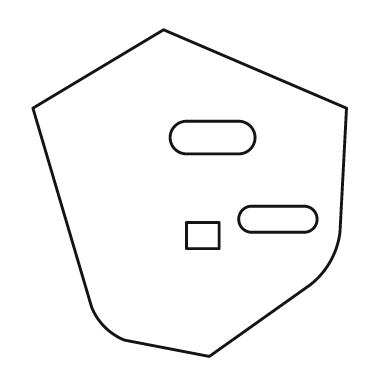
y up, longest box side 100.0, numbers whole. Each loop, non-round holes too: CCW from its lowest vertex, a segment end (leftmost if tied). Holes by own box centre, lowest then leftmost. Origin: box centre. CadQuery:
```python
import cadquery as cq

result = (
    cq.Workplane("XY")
    .moveTo(6.0, -50.0)
    .lineTo(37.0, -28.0)
    .threePointArc((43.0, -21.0), (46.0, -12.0))
    .lineTo(48.0, 26.0)
    .lineTo(-8.0, 50.0)
    .lineTo(-48.0, 26.0)
    .lineTo(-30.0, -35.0)
    .threePointArc((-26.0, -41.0), (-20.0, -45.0))
    .close()
    .moveTo(-1.0, -17.0)
    .lineTo(9.0, -17.0)
    .lineTo(9.0, -9.0)
    .lineTo(-1.0, -9.0)
    .close()
    .moveTo(19.0, -12.0)
    .lineTo(35.0, -12.0)
    .threePointArc((39.0, -8.0), (35.0, -4.0))
    .lineTo(19.0, -4.0)
    .threePointArc((15.0, -8.0), (19.0, -12.0))
    .close()
    .moveTo(-1.0, 12.0)
    .lineTo(15.0, 12.0)
    .threePointArc((20.0, 17.0), (15.0, 22.0))
    .lineTo(-1.0, 22.0)
    .threePointArc((-6.0, 17.0), (-1.0, 12.0))
    .close()
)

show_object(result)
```